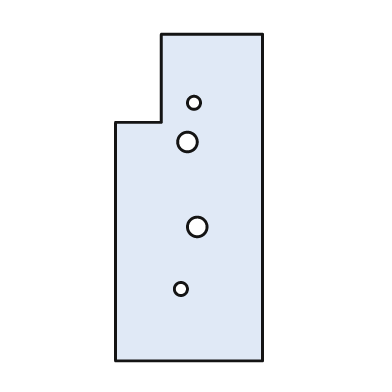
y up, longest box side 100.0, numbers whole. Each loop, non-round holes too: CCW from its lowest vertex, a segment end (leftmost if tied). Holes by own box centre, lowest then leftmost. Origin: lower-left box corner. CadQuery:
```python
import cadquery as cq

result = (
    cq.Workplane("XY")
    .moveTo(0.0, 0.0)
    .lineTo(45.0, 0.0)
    .lineTo(45.0, 100.0)
    .lineTo(14.0, 100.0)
    .lineTo(14.0, 73.0)
    .lineTo(0.0, 73.0)
    .close()
    .moveTo(20.0, 22.0)
    .circle(2.0)
    .moveTo(25.0, 41.0)
    .circle(3.0)
    .moveTo(22.0, 67.0)
    .circle(3.0)
    .moveTo(24.0, 79.0)
    .circle(2.0)
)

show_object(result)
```